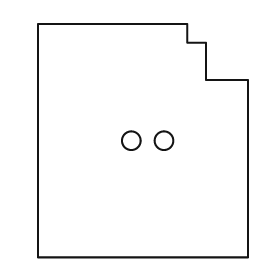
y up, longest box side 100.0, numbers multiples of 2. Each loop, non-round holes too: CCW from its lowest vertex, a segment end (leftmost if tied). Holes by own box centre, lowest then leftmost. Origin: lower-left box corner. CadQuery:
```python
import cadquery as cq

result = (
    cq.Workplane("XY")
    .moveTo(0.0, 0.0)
    .lineTo(90.0, 0.0)
    .lineTo(90.0, 76.0)
    .lineTo(72.0, 76.0)
    .lineTo(72.0, 92.0)
    .lineTo(64.0, 92.0)
    .lineTo(64.0, 100.0)
    .lineTo(0.0, 100.0)
    .close()
    .moveTo(40.0, 50.0)
    .circle(4.0)
    .moveTo(54.0, 50.0)
    .circle(4.0)
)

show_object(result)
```